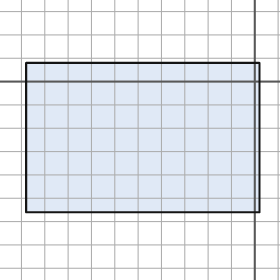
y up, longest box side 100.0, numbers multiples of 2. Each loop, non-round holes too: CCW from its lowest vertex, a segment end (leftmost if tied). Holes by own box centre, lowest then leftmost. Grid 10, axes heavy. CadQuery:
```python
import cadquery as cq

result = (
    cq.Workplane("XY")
    .moveTo(-98.0, -56.0)
    .lineTo(2.0, -56.0)
    .lineTo(2.0, 8.0)
    .lineTo(-98.0, 8.0)
    .close()
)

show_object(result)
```